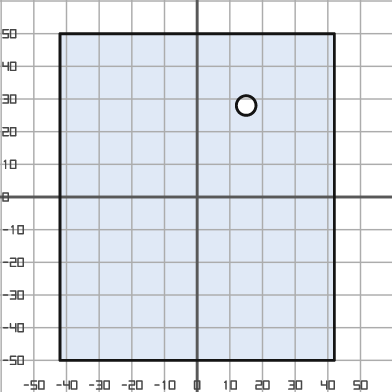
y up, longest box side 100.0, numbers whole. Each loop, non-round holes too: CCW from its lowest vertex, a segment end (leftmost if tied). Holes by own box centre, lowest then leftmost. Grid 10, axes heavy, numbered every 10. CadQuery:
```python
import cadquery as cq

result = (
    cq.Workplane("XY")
    .moveTo(-42.0, -50.0)
    .lineTo(42.0, -50.0)
    .lineTo(42.0, 50.0)
    .lineTo(-42.0, 50.0)
    .close()
    .moveTo(15.0, 28.0)
    .circle(3.0)
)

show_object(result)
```